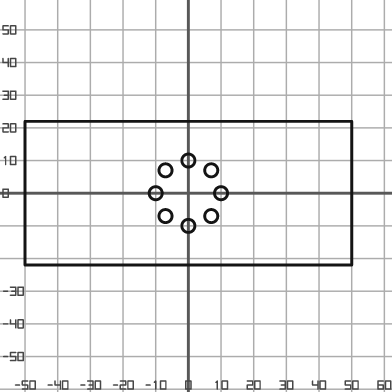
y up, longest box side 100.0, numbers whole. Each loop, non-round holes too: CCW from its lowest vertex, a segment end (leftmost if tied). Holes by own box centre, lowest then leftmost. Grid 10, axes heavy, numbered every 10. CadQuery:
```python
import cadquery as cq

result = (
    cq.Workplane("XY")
    .moveTo(-50.0, -22.0)
    .lineTo(50.0, -22.0)
    .lineTo(50.0, 22.0)
    .lineTo(-50.0, 22.0)
    .close()
    .moveTo(0.0, -10.0)
    .circle(2.0)
    .moveTo(-7.0, -7.0)
    .circle(2.0)
    .moveTo(7.0, -7.0)
    .circle(2.0)
    .moveTo(-10.0, 0.0)
    .circle(2.0)
    .moveTo(10.0, 0.0)
    .circle(2.0)
    .moveTo(-7.0, 7.0)
    .circle(2.0)
    .moveTo(7.0, 7.0)
    .circle(2.0)
    .moveTo(0.0, 10.0)
    .circle(2.0)
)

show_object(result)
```